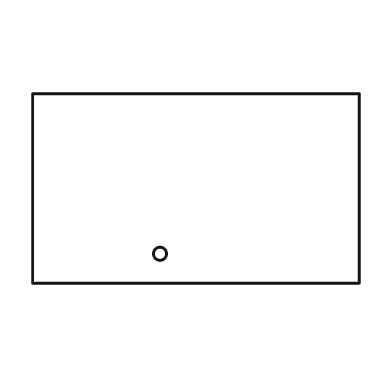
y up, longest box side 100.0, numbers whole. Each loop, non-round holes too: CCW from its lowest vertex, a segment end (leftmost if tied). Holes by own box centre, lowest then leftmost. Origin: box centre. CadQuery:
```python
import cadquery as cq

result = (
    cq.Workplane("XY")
    .moveTo(-50.0, -29.0)
    .lineTo(50.0, -29.0)
    .lineTo(50.0, 29.0)
    .lineTo(-50.0, 29.0)
    .close()
    .moveTo(-11.0, -20.0)
    .circle(2.0)
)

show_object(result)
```